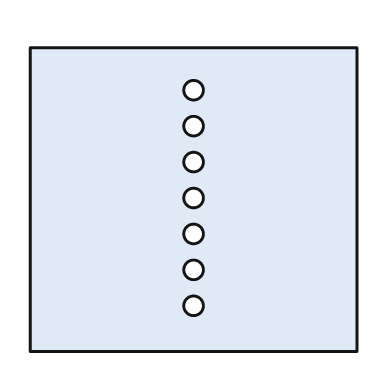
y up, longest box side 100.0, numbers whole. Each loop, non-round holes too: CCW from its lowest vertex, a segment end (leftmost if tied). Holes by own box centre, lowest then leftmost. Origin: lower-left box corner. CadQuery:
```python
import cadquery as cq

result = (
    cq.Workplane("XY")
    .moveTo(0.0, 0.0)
    .lineTo(100.0, 0.0)
    .lineTo(100.0, 93.0)
    .lineTo(0.0, 93.0)
    .close()
    .moveTo(50.0, 14.0)
    .circle(3.0)
    .moveTo(50.0, 25.0)
    .circle(3.0)
    .moveTo(50.0, 36.0)
    .circle(3.0)
    .moveTo(50.0, 47.0)
    .circle(3.0)
    .moveTo(50.0, 58.0)
    .circle(3.0)
    .moveTo(50.0, 69.0)
    .circle(3.0)
    .moveTo(50.0, 80.0)
    .circle(3.0)
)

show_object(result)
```